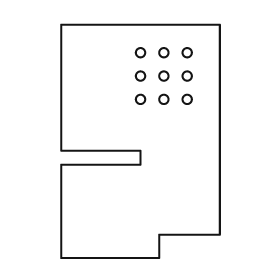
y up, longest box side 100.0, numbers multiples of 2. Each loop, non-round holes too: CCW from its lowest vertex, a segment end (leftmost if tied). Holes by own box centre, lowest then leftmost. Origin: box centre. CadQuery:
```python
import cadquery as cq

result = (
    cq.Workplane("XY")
    .moveTo(-34.0, -50.0)
    .lineTo(8.0, -50.0)
    .lineTo(8.0, -40.0)
    .lineTo(34.0, -40.0)
    .lineTo(34.0, 50.0)
    .lineTo(-34.0, 50.0)
    .lineTo(-34.0, -4.0)
    .lineTo(0.0, -4.0)
    .lineTo(0.0, -10.0)
    .lineTo(-34.0, -10.0)
    .close()
    .moveTo(0.0, 18.0)
    .circle(2.0)
    .moveTo(10.0, 18.0)
    .circle(2.0)
    .moveTo(20.0, 18.0)
    .circle(2.0)
    .moveTo(0.0, 28.0)
    .circle(2.0)
    .moveTo(10.0, 28.0)
    .circle(2.0)
    .moveTo(20.0, 28.0)
    .circle(2.0)
    .moveTo(0.0, 38.0)
    .circle(2.0)
    .moveTo(10.0, 38.0)
    .circle(2.0)
    .moveTo(20.0, 38.0)
    .circle(2.0)
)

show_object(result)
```